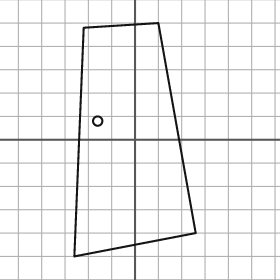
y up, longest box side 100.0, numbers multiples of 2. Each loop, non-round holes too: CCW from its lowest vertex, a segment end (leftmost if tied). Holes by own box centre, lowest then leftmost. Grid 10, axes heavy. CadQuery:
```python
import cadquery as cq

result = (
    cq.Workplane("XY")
    .moveTo(-26.0, -50.0)
    .lineTo(26.0, -40.0)
    .lineTo(10.0, 50.0)
    .lineTo(-22.0, 48.0)
    .close()
    .moveTo(-16.0, 8.0)
    .circle(2.0)
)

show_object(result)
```